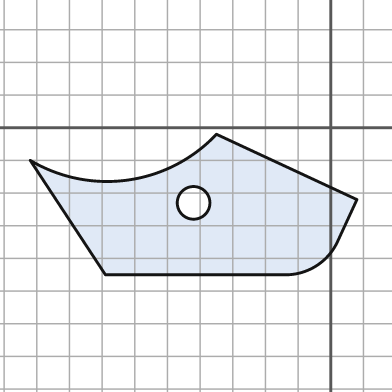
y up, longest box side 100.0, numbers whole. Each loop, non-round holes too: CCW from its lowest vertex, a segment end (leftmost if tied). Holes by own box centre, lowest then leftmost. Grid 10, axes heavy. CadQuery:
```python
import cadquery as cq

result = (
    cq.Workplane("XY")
    .moveTo(-69.0, -45.0)
    .lineTo(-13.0, -45.0)
    .threePointArc((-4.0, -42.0), (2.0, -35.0))
    .lineTo(8.0, -22.0)
    .lineTo(-35.0, -2.0)
    .threePointArc((-62.0, -16.0), (-92.0, -10.0))
    .close()
    .moveTo(-42.0, -23.0)
    .circle(5.0)
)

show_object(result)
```